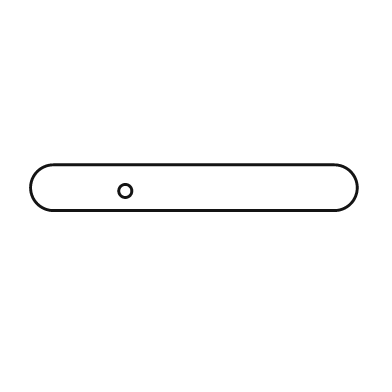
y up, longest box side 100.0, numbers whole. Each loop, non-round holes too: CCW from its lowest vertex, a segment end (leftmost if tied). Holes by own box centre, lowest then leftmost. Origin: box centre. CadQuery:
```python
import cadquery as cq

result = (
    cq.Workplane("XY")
    .moveTo(-43.0, -7.0)
    .lineTo(43.0, -7.0)
    .threePointArc((50.0, 0.0), (43.0, 7.0))
    .lineTo(-43.0, 7.0)
    .threePointArc((-50.0, 0.0), (-43.0, -7.0))
    .close()
    .moveTo(-21.0, -1.0)
    .circle(2.0)
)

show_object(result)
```